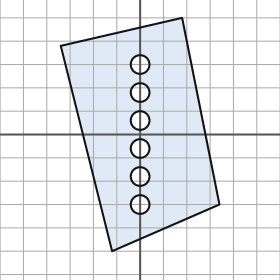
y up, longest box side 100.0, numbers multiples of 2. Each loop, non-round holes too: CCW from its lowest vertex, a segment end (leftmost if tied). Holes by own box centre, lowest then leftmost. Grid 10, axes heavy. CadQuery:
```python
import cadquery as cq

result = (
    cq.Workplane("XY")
    .moveTo(-12.0, -50.0)
    .lineTo(34.0, -30.0)
    .lineTo(18.0, 50.0)
    .lineTo(-34.0, 38.0)
    .close()
    .moveTo(0.0, -30.0)
    .circle(4.0)
    .moveTo(0.0, -18.0)
    .circle(4.0)
    .moveTo(0.0, -6.0)
    .circle(4.0)
    .moveTo(0.0, 6.0)
    .circle(4.0)
    .moveTo(0.0, 18.0)
    .circle(4.0)
    .moveTo(0.0, 30.0)
    .circle(4.0)
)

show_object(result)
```